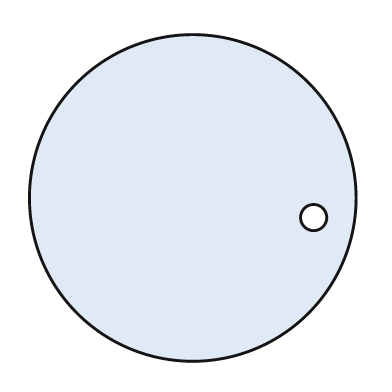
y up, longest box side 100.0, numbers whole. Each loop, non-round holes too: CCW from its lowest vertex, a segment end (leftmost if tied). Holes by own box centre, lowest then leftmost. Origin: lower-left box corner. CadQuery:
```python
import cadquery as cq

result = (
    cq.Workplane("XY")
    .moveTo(50.0, 50.0)
    .circle(50.0)
    .moveTo(87.0, 44.0)
    .circle(4.0)
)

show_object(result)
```